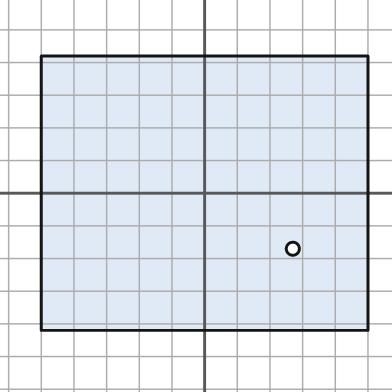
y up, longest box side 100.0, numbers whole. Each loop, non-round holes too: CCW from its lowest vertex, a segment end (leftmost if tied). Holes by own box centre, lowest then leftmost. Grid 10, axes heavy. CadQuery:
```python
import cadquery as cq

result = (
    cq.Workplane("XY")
    .moveTo(-50.0, -42.0)
    .lineTo(50.0, -42.0)
    .lineTo(50.0, 42.0)
    .lineTo(-50.0, 42.0)
    .close()
    .moveTo(27.0, -17.0)
    .circle(2.0)
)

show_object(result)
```